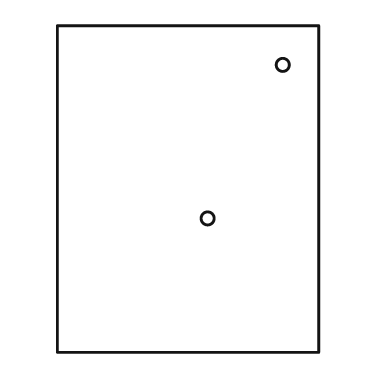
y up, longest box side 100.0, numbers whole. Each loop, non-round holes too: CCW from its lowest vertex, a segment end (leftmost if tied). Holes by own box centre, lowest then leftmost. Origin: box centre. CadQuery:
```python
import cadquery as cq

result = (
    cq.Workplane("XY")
    .moveTo(-40.0, -50.0)
    .lineTo(40.0, -50.0)
    .lineTo(40.0, 50.0)
    .lineTo(-40.0, 50.0)
    .close()
    .moveTo(6.0, -9.0)
    .circle(2.0)
    .moveTo(29.0, 38.0)
    .circle(2.0)
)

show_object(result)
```